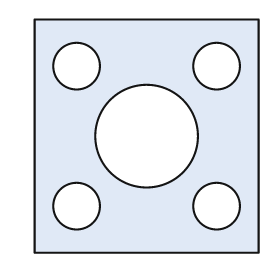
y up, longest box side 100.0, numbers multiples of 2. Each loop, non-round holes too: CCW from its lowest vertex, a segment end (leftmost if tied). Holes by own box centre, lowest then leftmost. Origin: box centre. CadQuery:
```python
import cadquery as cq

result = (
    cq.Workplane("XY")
    .moveTo(-48.0, -50.0)
    .lineTo(48.0, -50.0)
    .lineTo(48.0, 50.0)
    .lineTo(-48.0, 50.0)
    .close()
    .moveTo(-30.0, -30.0)
    .circle(10.0)
    .moveTo(30.0, -30.0)
    .circle(10.0)
    .moveTo(0.0, 0.0)
    .circle(22.0)
    .moveTo(-30.0, 30.0)
    .circle(10.0)
    .moveTo(30.0, 30.0)
    .circle(10.0)
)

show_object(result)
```